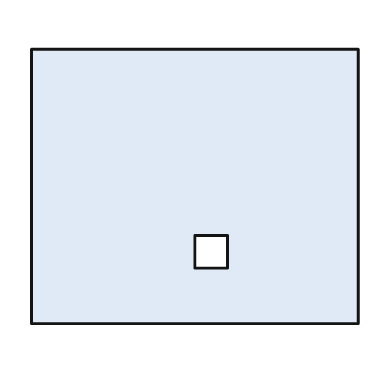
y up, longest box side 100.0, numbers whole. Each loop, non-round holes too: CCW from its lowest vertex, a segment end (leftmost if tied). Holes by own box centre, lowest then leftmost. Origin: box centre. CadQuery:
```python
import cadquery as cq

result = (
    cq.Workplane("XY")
    .moveTo(-50.0, -42.0)
    .lineTo(50.0, -42.0)
    .lineTo(50.0, 42.0)
    .lineTo(-50.0, 42.0)
    .close()
    .moveTo(0.0, -25.0)
    .lineTo(10.0, -25.0)
    .lineTo(10.0, -15.0)
    .lineTo(0.0, -15.0)
    .close()
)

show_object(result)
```